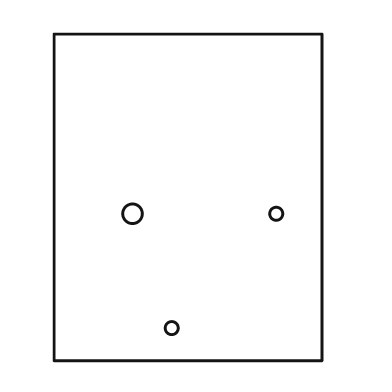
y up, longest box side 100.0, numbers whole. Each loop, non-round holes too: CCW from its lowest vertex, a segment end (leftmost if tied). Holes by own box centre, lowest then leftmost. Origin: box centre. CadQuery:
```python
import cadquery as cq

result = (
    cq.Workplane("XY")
    .moveTo(-41.0, -50.0)
    .lineTo(41.0, -50.0)
    .lineTo(41.0, 50.0)
    .lineTo(-41.0, 50.0)
    .close()
    .moveTo(-5.0, -40.0)
    .circle(2.0)
    .moveTo(-17.0, -5.0)
    .circle(3.0)
    .moveTo(27.0, -5.0)
    .circle(2.0)
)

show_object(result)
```